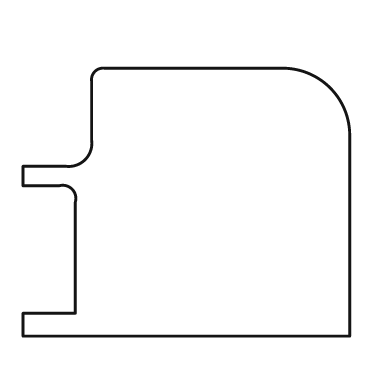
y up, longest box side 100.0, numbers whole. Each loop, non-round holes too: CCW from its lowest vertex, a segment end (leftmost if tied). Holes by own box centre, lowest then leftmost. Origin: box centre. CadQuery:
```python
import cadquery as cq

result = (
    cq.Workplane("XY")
    .moveTo(-50.0, -41.0)
    .lineTo(50.0, -41.0)
    .lineTo(50.0, 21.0)
    .threePointArc((44.0, 35.0), (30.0, 41.0))
    .lineTo(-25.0, 41.0)
    .threePointArc((-28.0, 40.0), (-29.0, 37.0))
    .lineTo(-29.0, 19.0)
    .threePointArc((-31.0, 13.0), (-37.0, 11.0))
    .lineTo(-50.0, 11.0)
    .lineTo(-50.0, 5.0)
    .lineTo(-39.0, 5.0)
    .threePointArc((-35.0, 4.0), (-34.0, 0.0))
    .lineTo(-34.0, -34.0)
    .lineTo(-50.0, -34.0)
    .close()
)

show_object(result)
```